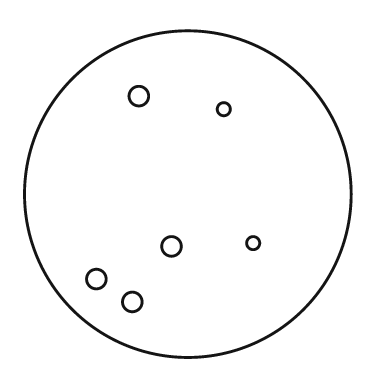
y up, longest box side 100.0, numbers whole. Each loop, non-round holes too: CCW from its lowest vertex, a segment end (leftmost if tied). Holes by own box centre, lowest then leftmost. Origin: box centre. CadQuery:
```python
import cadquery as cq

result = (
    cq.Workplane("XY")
    .moveTo(0.0, 0.0)
    .circle(50.0)
    .moveTo(-17.0, -33.0)
    .circle(3.0)
    .moveTo(-28.0, -26.0)
    .circle(3.0)
    .moveTo(-5.0, -16.0)
    .circle(3.0)
    .moveTo(20.0, -15.0)
    .circle(2.0)
    .moveTo(11.0, 26.0)
    .circle(2.0)
    .moveTo(-15.0, 30.0)
    .circle(3.0)
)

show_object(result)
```